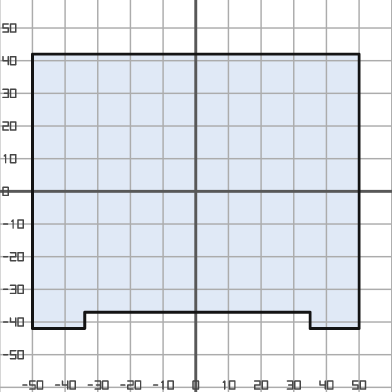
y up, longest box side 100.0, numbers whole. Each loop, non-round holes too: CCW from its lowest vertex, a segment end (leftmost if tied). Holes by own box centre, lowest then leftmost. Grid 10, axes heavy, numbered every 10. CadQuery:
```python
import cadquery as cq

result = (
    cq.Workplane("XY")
    .moveTo(-50.0, -42.0)
    .lineTo(-34.0, -42.0)
    .lineTo(-34.0, -37.0)
    .lineTo(35.0, -37.0)
    .lineTo(35.0, -42.0)
    .lineTo(50.0, -42.0)
    .lineTo(50.0, 42.0)
    .lineTo(-50.0, 42.0)
    .close()
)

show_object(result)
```